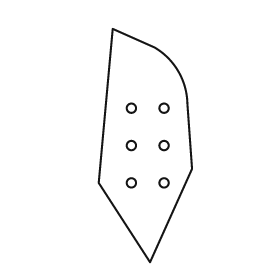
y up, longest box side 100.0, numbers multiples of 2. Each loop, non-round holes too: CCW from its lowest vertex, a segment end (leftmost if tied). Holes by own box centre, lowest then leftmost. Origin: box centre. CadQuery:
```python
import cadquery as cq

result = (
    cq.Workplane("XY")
    .moveTo(2.0, -50.0)
    .lineTo(20.0, -10.0)
    .lineTo(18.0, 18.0)
    .threePointArc((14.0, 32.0), (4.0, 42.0))
    .lineTo(-14.0, 50.0)
    .lineTo(-20.0, -16.0)
    .close()
    .moveTo(-6.0, -16.0)
    .circle(2.0)
    .moveTo(8.0, -16.0)
    .circle(2.0)
    .moveTo(-6.0, 0.0)
    .circle(2.0)
    .moveTo(8.0, 0.0)
    .circle(2.0)
    .moveTo(-6.0, 16.0)
    .circle(2.0)
    .moveTo(8.0, 16.0)
    .circle(2.0)
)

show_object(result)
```